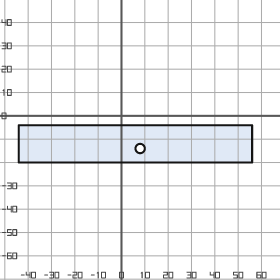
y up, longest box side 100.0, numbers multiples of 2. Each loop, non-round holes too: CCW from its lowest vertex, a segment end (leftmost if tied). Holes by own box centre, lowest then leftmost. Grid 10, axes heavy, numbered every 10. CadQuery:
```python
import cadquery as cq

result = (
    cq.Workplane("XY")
    .moveTo(-44.0, -20.0)
    .lineTo(56.0, -20.0)
    .lineTo(56.0, -4.0)
    .lineTo(-44.0, -4.0)
    .close()
    .moveTo(8.0, -14.0)
    .circle(2.0)
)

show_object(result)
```